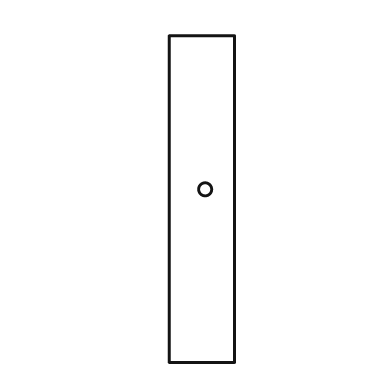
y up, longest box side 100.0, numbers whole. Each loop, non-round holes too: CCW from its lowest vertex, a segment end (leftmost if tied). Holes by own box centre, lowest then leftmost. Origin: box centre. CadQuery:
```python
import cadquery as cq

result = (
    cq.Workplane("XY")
    .moveTo(-10.0, -50.0)
    .lineTo(10.0, -50.0)
    .lineTo(10.0, 50.0)
    .lineTo(-10.0, 50.0)
    .close()
    .moveTo(1.0, 3.0)
    .circle(2.0)
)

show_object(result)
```